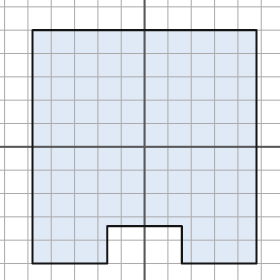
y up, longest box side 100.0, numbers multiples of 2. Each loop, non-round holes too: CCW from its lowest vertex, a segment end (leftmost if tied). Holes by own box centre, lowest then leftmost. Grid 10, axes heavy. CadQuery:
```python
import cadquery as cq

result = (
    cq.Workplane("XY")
    .moveTo(-48.0, -50.0)
    .lineTo(-16.0, -50.0)
    .lineTo(-16.0, -34.0)
    .lineTo(16.0, -34.0)
    .lineTo(16.0, -50.0)
    .lineTo(48.0, -50.0)
    .lineTo(48.0, 50.0)
    .lineTo(-48.0, 50.0)
    .close()
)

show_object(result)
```